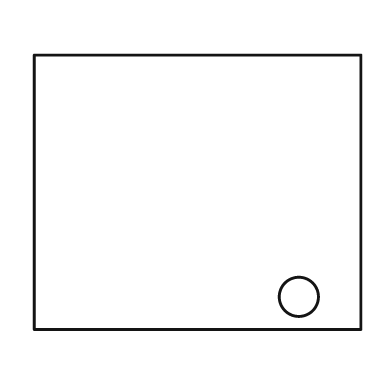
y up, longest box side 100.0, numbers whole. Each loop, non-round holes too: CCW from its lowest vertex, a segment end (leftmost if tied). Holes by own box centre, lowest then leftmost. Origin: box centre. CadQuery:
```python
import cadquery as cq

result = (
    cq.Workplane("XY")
    .moveTo(-50.0, -42.0)
    .lineTo(50.0, -42.0)
    .lineTo(50.0, 42.0)
    .lineTo(-50.0, 42.0)
    .close()
    .moveTo(31.0, -32.0)
    .circle(6.0)
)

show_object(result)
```